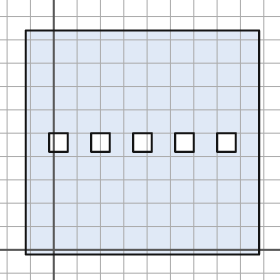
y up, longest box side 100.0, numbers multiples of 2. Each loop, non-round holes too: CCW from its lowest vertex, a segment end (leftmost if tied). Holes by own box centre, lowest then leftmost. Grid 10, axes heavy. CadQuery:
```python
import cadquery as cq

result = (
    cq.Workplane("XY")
    .moveTo(-12.0, -2.0)
    .lineTo(88.0, -2.0)
    .lineTo(88.0, 94.0)
    .lineTo(-12.0, 94.0)
    .close()
    .moveTo(-2.0, 42.0)
    .lineTo(6.0, 42.0)
    .lineTo(6.0, 50.0)
    .lineTo(-2.0, 50.0)
    .close()
    .moveTo(16.0, 42.0)
    .lineTo(24.0, 42.0)
    .lineTo(24.0, 50.0)
    .lineTo(16.0, 50.0)
    .close()
    .moveTo(34.0, 42.0)
    .lineTo(42.0, 42.0)
    .lineTo(42.0, 50.0)
    .lineTo(34.0, 50.0)
    .close()
    .moveTo(52.0, 42.0)
    .lineTo(60.0, 42.0)
    .lineTo(60.0, 50.0)
    .lineTo(52.0, 50.0)
    .close()
    .moveTo(70.0, 42.0)
    .lineTo(78.0, 42.0)
    .lineTo(78.0, 50.0)
    .lineTo(70.0, 50.0)
    .close()
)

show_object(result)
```